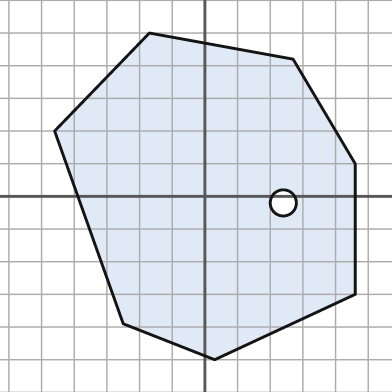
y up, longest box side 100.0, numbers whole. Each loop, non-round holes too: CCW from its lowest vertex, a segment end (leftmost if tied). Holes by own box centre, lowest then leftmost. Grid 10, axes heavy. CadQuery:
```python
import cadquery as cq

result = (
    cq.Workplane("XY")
    .moveTo(3.0, -50.0)
    .lineTo(46.0, -30.0)
    .lineTo(46.0, 10.0)
    .lineTo(27.0, 42.0)
    .lineTo(-17.0, 50.0)
    .lineTo(-46.0, 20.0)
    .lineTo(-25.0, -39.0)
    .close()
    .moveTo(24.0, -2.0)
    .circle(4.0)
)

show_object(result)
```